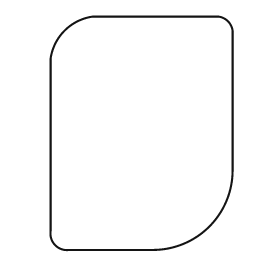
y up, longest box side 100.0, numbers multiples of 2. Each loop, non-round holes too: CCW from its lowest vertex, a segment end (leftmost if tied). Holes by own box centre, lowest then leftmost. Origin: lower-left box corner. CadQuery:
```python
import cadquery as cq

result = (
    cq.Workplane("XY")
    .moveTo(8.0, 0.0)
    .lineTo(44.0, 0.0)
    .threePointArc((68.0, 10.0), (78.0, 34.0))
    .lineTo(78.0, 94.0)
    .threePointArc((76.0, 98.0), (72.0, 100.0))
    .lineTo(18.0, 100.0)
    .threePointArc((6.0, 94.0), (0.0, 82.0))
    .lineTo(0.0, 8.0)
    .threePointArc((2.0, 2.0), (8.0, 0.0))
    .close()
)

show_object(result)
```